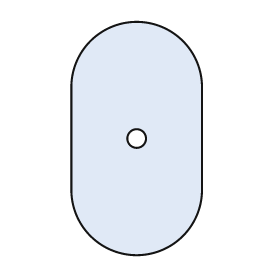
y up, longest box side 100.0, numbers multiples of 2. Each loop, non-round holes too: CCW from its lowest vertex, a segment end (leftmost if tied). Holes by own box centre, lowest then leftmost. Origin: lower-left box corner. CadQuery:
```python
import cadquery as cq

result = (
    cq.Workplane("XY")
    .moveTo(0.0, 28.0)
    .threePointArc((28.0, 0.0), (56.0, 28.0))
    .lineTo(56.0, 72.0)
    .threePointArc((28.0, 100.0), (0.0, 72.0))
    .close()
    .moveTo(28.0, 50.0)
    .circle(4.0)
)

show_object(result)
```